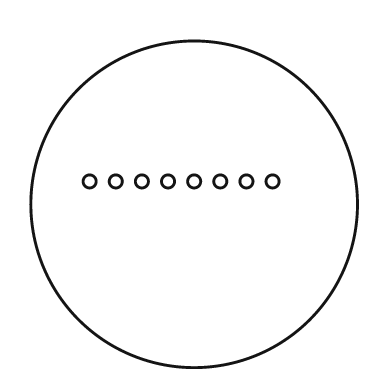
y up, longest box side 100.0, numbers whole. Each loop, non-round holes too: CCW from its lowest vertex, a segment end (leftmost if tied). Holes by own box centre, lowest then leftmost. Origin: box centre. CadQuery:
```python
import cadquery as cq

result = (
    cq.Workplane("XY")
    .moveTo(0.0, 0.0)
    .circle(50.0)
    .moveTo(-32.0, 7.0)
    .circle(2.0)
    .moveTo(-24.0, 7.0)
    .circle(2.0)
    .moveTo(-16.0, 7.0)
    .circle(2.0)
    .moveTo(-8.0, 7.0)
    .circle(2.0)
    .moveTo(0.0, 7.0)
    .circle(2.0)
    .moveTo(8.0, 7.0)
    .circle(2.0)
    .moveTo(16.0, 7.0)
    .circle(2.0)
    .moveTo(24.0, 7.0)
    .circle(2.0)
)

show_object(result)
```